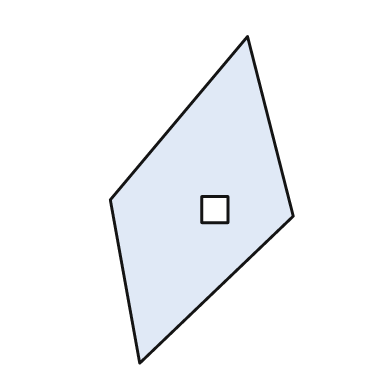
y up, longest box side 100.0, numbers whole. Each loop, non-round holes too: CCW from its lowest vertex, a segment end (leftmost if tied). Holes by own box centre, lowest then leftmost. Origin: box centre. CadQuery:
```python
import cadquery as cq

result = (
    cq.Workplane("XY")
    .moveTo(-19.0, -50.0)
    .lineTo(28.0, -5.0)
    .lineTo(14.0, 50.0)
    .lineTo(-28.0, 0.0)
    .close()
    .moveTo(0.0, -7.0)
    .lineTo(8.0, -7.0)
    .lineTo(8.0, 1.0)
    .lineTo(0.0, 1.0)
    .close()
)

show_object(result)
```